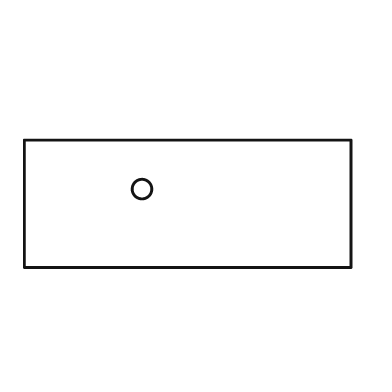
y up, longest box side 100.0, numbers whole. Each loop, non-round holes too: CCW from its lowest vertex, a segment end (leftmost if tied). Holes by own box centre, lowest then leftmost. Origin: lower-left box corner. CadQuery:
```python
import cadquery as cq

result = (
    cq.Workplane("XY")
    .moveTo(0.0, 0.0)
    .lineTo(100.0, 0.0)
    .lineTo(100.0, 39.0)
    .lineTo(0.0, 39.0)
    .close()
    .moveTo(36.0, 24.0)
    .circle(3.0)
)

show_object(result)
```